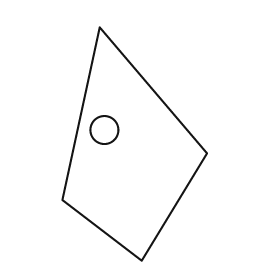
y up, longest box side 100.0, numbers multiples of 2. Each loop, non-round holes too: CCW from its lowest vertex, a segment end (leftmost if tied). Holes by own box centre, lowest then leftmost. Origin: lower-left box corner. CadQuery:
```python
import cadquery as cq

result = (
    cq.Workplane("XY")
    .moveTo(34.0, 0.0)
    .lineTo(62.0, 46.0)
    .lineTo(16.0, 100.0)
    .lineTo(0.0, 26.0)
    .close()
    .moveTo(18.0, 56.0)
    .circle(6.0)
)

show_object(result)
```